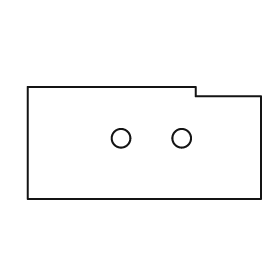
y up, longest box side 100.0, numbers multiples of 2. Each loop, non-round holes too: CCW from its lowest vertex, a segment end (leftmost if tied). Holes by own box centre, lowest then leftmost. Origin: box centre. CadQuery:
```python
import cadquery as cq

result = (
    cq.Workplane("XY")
    .moveTo(-50.0, -24.0)
    .lineTo(50.0, -24.0)
    .lineTo(50.0, 20.0)
    .lineTo(22.0, 20.0)
    .lineTo(22.0, 24.0)
    .lineTo(-50.0, 24.0)
    .close()
    .moveTo(-10.0, 2.0)
    .circle(4.0)
    .moveTo(16.0, 2.0)
    .circle(4.0)
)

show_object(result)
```